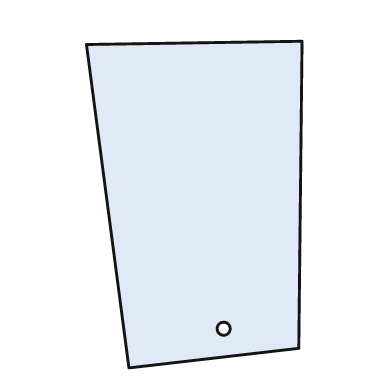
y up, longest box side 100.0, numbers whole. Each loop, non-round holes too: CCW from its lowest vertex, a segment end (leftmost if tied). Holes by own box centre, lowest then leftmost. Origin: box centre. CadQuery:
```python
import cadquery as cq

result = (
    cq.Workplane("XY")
    .moveTo(-20.0, -50.0)
    .lineTo(32.0, -44.0)
    .lineTo(33.0, 50.0)
    .lineTo(-33.0, 49.0)
    .close()
    .moveTo(9.0, -38.0)
    .circle(2.0)
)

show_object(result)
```